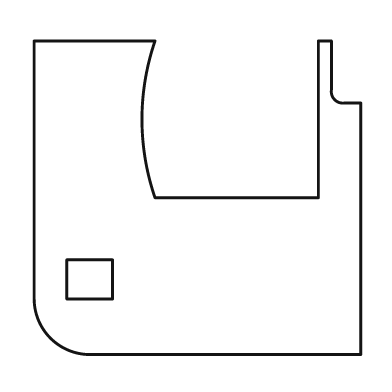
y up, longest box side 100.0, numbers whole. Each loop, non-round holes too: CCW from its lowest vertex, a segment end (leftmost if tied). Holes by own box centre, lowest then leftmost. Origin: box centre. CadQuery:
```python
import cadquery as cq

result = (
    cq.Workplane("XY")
    .moveTo(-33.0, -48.0)
    .lineTo(50.0, -48.0)
    .lineTo(50.0, 29.0)
    .lineTo(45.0, 29.0)
    .threePointArc((42.0, 30.0), (41.0, 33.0))
    .lineTo(41.0, 48.0)
    .lineTo(37.0, 48.0)
    .lineTo(37.0, 0.0)
    .lineTo(-13.0, 0.0)
    .threePointArc((-17.0, 24.0), (-13.0, 48.0))
    .lineTo(-50.0, 48.0)
    .lineTo(-50.0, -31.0)
    .threePointArc((-45.0, -43.0), (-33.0, -48.0))
    .close()
    .moveTo(-40.0, -31.0)
    .lineTo(-26.0, -31.0)
    .lineTo(-26.0, -19.0)
    .lineTo(-40.0, -19.0)
    .close()
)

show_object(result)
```